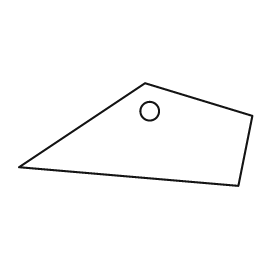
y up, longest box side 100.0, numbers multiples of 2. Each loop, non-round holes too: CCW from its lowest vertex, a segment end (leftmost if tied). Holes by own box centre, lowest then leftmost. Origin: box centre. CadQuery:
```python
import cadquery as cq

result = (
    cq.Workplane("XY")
    .moveTo(44.0, -22.0)
    .lineTo(50.0, 8.0)
    .lineTo(4.0, 22.0)
    .lineTo(-50.0, -14.0)
    .close()
    .moveTo(6.0, 10.0)
    .circle(4.0)
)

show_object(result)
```